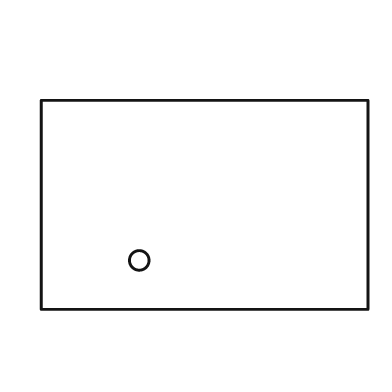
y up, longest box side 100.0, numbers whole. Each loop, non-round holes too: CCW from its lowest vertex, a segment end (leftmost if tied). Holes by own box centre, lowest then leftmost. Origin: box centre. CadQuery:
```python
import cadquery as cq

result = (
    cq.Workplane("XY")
    .moveTo(-50.0, -32.0)
    .lineTo(50.0, -32.0)
    .lineTo(50.0, 32.0)
    .lineTo(-50.0, 32.0)
    .close()
    .moveTo(-20.0, -17.0)
    .circle(3.0)
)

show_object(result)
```